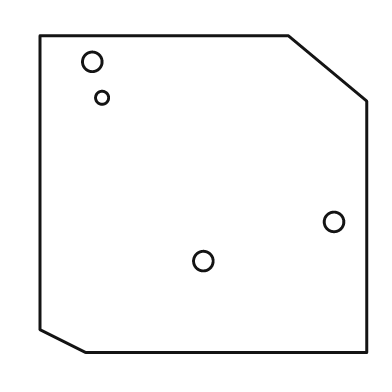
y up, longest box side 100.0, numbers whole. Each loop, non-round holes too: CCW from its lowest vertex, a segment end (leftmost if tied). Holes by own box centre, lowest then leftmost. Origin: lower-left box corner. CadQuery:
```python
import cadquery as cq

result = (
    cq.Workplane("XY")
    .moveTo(14.0, 0.0)
    .lineTo(100.0, 0.0)
    .lineTo(100.0, 77.0)
    .lineTo(76.0, 97.0)
    .lineTo(0.0, 97.0)
    .lineTo(0.0, 7.0)
    .close()
    .moveTo(50.0, 28.0)
    .circle(3.0)
    .moveTo(90.0, 40.0)
    .circle(3.0)
    .moveTo(19.0, 78.0)
    .circle(2.0)
    .moveTo(16.0, 89.0)
    .circle(3.0)
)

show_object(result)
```